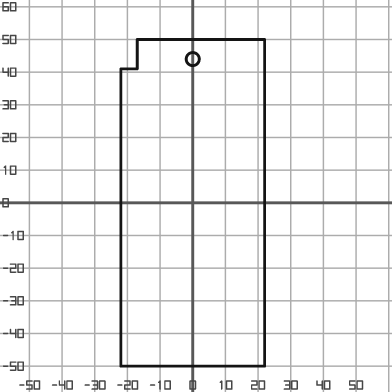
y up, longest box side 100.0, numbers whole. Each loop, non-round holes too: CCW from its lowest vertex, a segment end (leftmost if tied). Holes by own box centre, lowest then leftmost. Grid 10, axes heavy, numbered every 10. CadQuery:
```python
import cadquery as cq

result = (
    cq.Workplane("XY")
    .moveTo(-22.0, -50.0)
    .lineTo(22.0, -50.0)
    .lineTo(22.0, 50.0)
    .lineTo(-17.0, 50.0)
    .lineTo(-17.0, 41.0)
    .lineTo(-22.0, 41.0)
    .close()
    .moveTo(0.0, 44.0)
    .circle(2.0)
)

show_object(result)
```